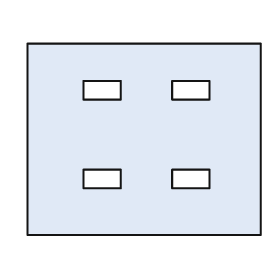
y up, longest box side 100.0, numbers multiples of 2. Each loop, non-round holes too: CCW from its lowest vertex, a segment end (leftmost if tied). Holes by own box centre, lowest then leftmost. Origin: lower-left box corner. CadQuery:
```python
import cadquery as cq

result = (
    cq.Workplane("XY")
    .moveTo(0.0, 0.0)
    .lineTo(100.0, 0.0)
    .lineTo(100.0, 82.0)
    .lineTo(0.0, 82.0)
    .close()
    .moveTo(24.0, 20.0)
    .lineTo(40.0, 20.0)
    .lineTo(40.0, 28.0)
    .lineTo(24.0, 28.0)
    .close()
    .moveTo(62.0, 20.0)
    .lineTo(78.0, 20.0)
    .lineTo(78.0, 28.0)
    .lineTo(62.0, 28.0)
    .close()
    .moveTo(24.0, 58.0)
    .lineTo(40.0, 58.0)
    .lineTo(40.0, 66.0)
    .lineTo(24.0, 66.0)
    .close()
    .moveTo(62.0, 58.0)
    .lineTo(78.0, 58.0)
    .lineTo(78.0, 66.0)
    .lineTo(62.0, 66.0)
    .close()
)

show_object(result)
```